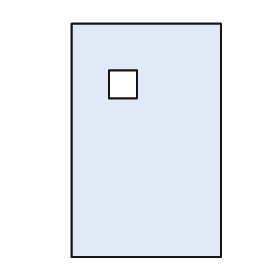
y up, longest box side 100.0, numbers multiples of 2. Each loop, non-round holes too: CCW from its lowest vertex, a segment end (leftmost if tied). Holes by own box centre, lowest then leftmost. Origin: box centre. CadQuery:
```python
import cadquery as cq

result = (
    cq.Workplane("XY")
    .moveTo(-32.0, -50.0)
    .lineTo(32.0, -50.0)
    .lineTo(32.0, 50.0)
    .lineTo(-32.0, 50.0)
    .close()
    .moveTo(-16.0, 18.0)
    .lineTo(-4.0, 18.0)
    .lineTo(-4.0, 30.0)
    .lineTo(-16.0, 30.0)
    .close()
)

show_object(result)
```